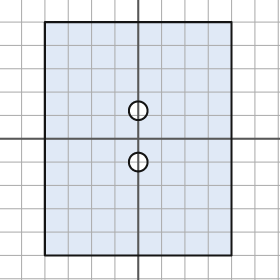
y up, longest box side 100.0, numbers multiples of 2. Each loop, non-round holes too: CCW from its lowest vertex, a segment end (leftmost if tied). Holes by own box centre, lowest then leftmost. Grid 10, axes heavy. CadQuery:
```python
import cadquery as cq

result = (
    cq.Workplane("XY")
    .moveTo(-40.0, -50.0)
    .lineTo(40.0, -50.0)
    .lineTo(40.0, 50.0)
    .lineTo(-40.0, 50.0)
    .close()
    .moveTo(0.0, -10.0)
    .circle(4.0)
    .moveTo(0.0, 12.0)
    .circle(4.0)
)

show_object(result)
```